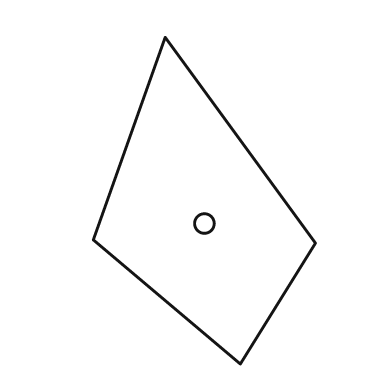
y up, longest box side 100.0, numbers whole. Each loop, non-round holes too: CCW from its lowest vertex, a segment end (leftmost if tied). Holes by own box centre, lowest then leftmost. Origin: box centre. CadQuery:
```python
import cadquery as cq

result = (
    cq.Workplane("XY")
    .moveTo(11.0, -50.0)
    .lineTo(34.0, -13.0)
    .lineTo(-12.0, 50.0)
    .lineTo(-34.0, -12.0)
    .close()
    .moveTo(0.0, -7.0)
    .circle(3.0)
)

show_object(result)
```